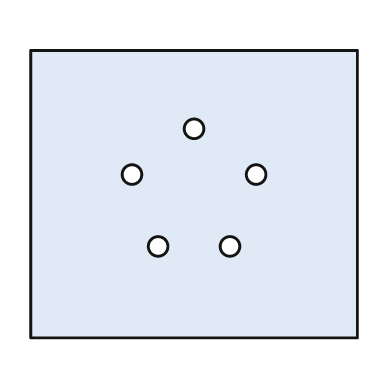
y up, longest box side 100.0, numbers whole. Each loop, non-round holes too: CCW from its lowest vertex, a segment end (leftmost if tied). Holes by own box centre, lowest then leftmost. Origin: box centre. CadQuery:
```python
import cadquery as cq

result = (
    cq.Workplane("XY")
    .moveTo(-50.0, -44.0)
    .lineTo(50.0, -44.0)
    .lineTo(50.0, 44.0)
    .lineTo(-50.0, 44.0)
    .close()
    .moveTo(-11.0, -16.0)
    .circle(3.0)
    .moveTo(11.0, -16.0)
    .circle(3.0)
    .moveTo(-19.0, 6.0)
    .circle(3.0)
    .moveTo(19.0, 6.0)
    .circle(3.0)
    .moveTo(0.0, 20.0)
    .circle(3.0)
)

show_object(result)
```